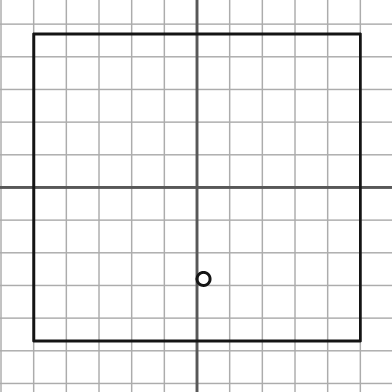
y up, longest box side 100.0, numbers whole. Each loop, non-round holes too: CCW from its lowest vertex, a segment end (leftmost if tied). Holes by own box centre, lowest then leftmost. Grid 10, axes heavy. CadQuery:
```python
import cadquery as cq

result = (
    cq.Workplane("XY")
    .moveTo(-50.0, -47.0)
    .lineTo(50.0, -47.0)
    .lineTo(50.0, 47.0)
    .lineTo(-50.0, 47.0)
    .close()
    .moveTo(2.0, -28.0)
    .circle(2.0)
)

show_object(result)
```